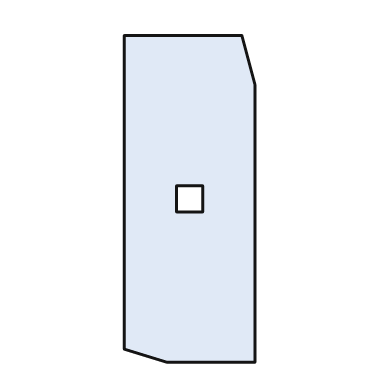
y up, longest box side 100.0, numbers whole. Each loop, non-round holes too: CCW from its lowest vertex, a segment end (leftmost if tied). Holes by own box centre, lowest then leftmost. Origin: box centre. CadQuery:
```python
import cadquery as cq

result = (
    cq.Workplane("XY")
    .moveTo(-7.0, -50.0)
    .lineTo(20.0, -50.0)
    .lineTo(20.0, 35.0)
    .lineTo(16.0, 50.0)
    .lineTo(-20.0, 50.0)
    .lineTo(-20.0, -46.0)
    .close()
    .moveTo(-4.0, -4.0)
    .lineTo(4.0, -4.0)
    .lineTo(4.0, 4.0)
    .lineTo(-4.0, 4.0)
    .close()
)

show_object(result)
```